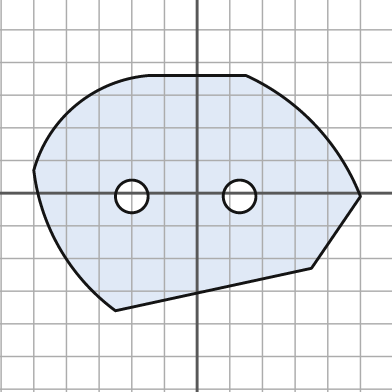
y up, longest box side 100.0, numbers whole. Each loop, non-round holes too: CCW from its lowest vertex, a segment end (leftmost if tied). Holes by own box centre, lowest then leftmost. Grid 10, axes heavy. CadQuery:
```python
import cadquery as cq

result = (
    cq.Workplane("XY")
    .moveTo(-25.0, -36.0)
    .lineTo(35.0, -23.0)
    .lineTo(50.0, -1.0)
    .threePointArc((36.0, 21.0), (15.0, 36.0))
    .lineTo(-15.0, 36.0)
    .threePointArc((-37.0, 27.0), (-50.0, 7.0))
    .threePointArc((-42.0, -17.0), (-25.0, -36.0))
    .close()
    .moveTo(-20.0, -1.0)
    .circle(5.0)
    .moveTo(13.0, -1.0)
    .circle(5.0)
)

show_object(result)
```